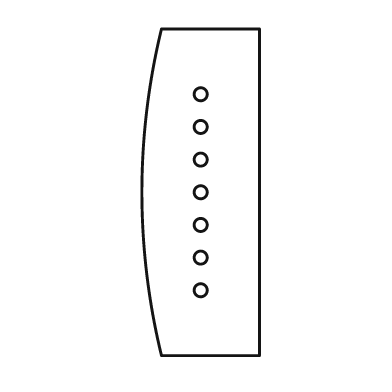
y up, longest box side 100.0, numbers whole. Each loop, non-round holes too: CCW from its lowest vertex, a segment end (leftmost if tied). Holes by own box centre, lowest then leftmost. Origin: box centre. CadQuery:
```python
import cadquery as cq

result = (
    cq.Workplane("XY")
    .moveTo(-12.0, -50.0)
    .lineTo(18.0, -50.0)
    .lineTo(18.0, 50.0)
    .lineTo(-12.0, 50.0)
    .threePointArc((-18.0, 0.0), (-12.0, -50.0))
    .close()
    .moveTo(0.0, -30.0)
    .circle(2.0)
    .moveTo(0.0, -20.0)
    .circle(2.0)
    .moveTo(0.0, -10.0)
    .circle(2.0)
    .moveTo(0.0, 0.0)
    .circle(2.0)
    .moveTo(0.0, 10.0)
    .circle(2.0)
    .moveTo(0.0, 20.0)
    .circle(2.0)
    .moveTo(0.0, 30.0)
    .circle(2.0)
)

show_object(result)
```